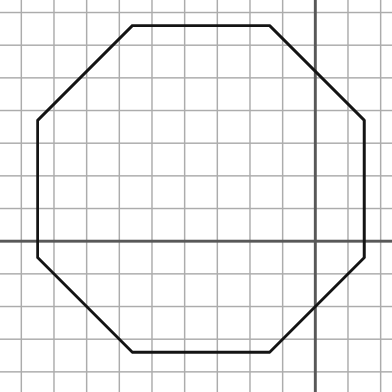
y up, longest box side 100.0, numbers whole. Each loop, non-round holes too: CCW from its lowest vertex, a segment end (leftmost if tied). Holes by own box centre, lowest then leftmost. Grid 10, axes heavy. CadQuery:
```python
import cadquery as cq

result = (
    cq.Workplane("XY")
    .moveTo(-56.0, -34.0)
    .lineTo(-14.0, -34.0)
    .lineTo(15.0, -5.0)
    .lineTo(15.0, 37.0)
    .lineTo(-14.0, 66.0)
    .lineTo(-56.0, 66.0)
    .lineTo(-85.0, 37.0)
    .lineTo(-85.0, -5.0)
    .close()
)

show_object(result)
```